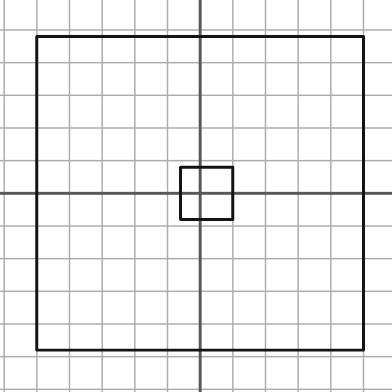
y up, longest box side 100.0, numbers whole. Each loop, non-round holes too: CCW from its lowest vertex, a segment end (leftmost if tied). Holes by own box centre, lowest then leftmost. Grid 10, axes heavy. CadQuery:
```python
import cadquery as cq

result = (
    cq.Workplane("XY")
    .moveTo(-50.0, -48.0)
    .lineTo(50.0, -48.0)
    .lineTo(50.0, 48.0)
    .lineTo(-50.0, 48.0)
    .close()
    .moveTo(-6.0, -8.0)
    .lineTo(10.0, -8.0)
    .lineTo(10.0, 8.0)
    .lineTo(-6.0, 8.0)
    .close()
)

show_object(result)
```